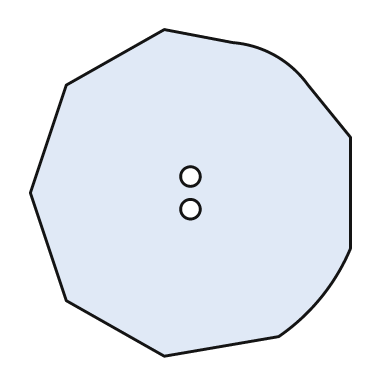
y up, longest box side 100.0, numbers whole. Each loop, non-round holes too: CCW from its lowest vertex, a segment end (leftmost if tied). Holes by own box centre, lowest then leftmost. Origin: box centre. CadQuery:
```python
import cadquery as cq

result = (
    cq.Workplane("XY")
    .moveTo(-8.0, -50.0)
    .lineTo(27.0, -44.0)
    .threePointArc((40.0, -32.0), (49.0, -17.0))
    .lineTo(49.0, 17.0)
    .lineTo(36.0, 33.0)
    .threePointArc((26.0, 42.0), (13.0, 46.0))
    .lineTo(-8.0, 50.0)
    .lineTo(-38.0, 33.0)
    .lineTo(-49.0, 0.0)
    .lineTo(-38.0, -33.0)
    .close()
    .moveTo(0.0, -5.0)
    .circle(3.0)
    .moveTo(0.0, 5.0)
    .circle(3.0)
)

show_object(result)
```